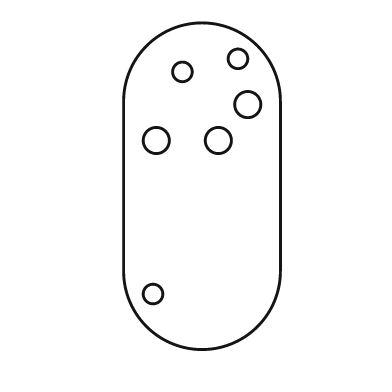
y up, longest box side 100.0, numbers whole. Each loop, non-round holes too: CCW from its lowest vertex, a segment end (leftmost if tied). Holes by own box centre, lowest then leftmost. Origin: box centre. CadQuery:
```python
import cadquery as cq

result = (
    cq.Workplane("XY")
    .moveTo(-24.0, -26.0)
    .threePointArc((0.0, -50.0), (24.0, -26.0))
    .lineTo(24.0, 26.0)
    .threePointArc((0.0, 50.0), (-24.0, 26.0))
    .close()
    .moveTo(-15.0, -33.0)
    .circle(3.0)
    .moveTo(-14.0, 14.0)
    .circle(4.0)
    .moveTo(5.0, 14.0)
    .circle(4.0)
    .moveTo(14.0, 25.0)
    .circle(4.0)
    .moveTo(-6.0, 35.0)
    .circle(3.0)
    .moveTo(11.0, 39.0)
    .circle(3.0)
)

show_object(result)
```